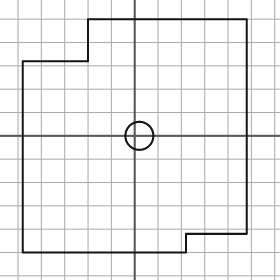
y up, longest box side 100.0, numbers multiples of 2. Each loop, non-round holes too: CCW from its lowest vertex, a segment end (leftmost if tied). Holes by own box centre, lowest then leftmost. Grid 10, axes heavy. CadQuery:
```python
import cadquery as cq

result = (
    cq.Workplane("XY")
    .moveTo(-48.0, -50.0)
    .lineTo(22.0, -50.0)
    .lineTo(22.0, -42.0)
    .lineTo(48.0, -42.0)
    .lineTo(48.0, 50.0)
    .lineTo(-20.0, 50.0)
    .lineTo(-20.0, 32.0)
    .lineTo(-48.0, 32.0)
    .close()
    .moveTo(2.0, 0.0)
    .circle(6.0)
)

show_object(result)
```